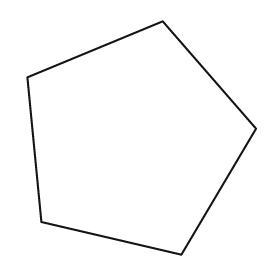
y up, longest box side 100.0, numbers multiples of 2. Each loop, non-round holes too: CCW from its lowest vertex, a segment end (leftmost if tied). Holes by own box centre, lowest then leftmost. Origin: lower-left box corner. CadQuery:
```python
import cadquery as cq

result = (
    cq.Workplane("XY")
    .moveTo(66.0, 0.0)
    .lineTo(98.0, 54.0)
    .lineTo(58.0, 100.0)
    .lineTo(0.0, 76.0)
    .lineTo(6.0, 14.0)
    .close()
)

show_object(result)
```